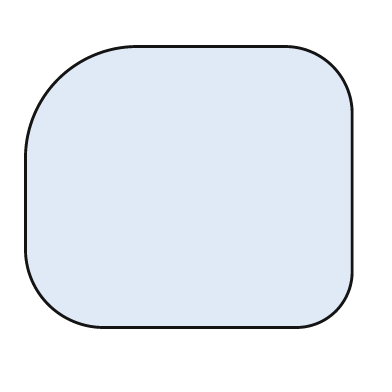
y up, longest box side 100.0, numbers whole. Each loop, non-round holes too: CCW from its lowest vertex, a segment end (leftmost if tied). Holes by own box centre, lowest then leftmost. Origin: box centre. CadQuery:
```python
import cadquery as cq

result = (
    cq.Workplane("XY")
    .moveTo(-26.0, -43.0)
    .lineTo(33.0, -43.0)
    .threePointArc((45.0, -38.0), (50.0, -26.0))
    .lineTo(50.0, 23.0)
    .threePointArc((44.0, 37.0), (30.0, 43.0))
    .lineTo(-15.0, 43.0)
    .threePointArc((-40.0, 33.0), (-50.0, 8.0))
    .lineTo(-50.0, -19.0)
    .threePointArc((-43.0, -36.0), (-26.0, -43.0))
    .close()
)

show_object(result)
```